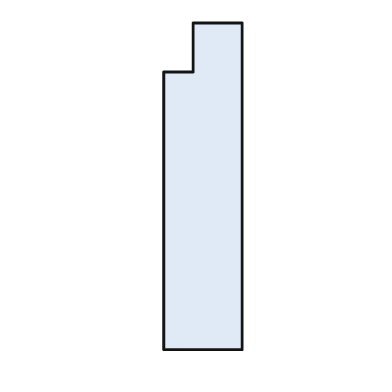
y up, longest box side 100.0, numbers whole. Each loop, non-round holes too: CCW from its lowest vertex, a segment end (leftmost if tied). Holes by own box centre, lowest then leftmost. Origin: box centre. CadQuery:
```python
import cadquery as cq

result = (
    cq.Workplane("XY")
    .moveTo(-12.0, -50.0)
    .lineTo(12.0, -50.0)
    .lineTo(12.0, 50.0)
    .lineTo(-3.0, 50.0)
    .lineTo(-3.0, 35.0)
    .lineTo(-12.0, 35.0)
    .close()
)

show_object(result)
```